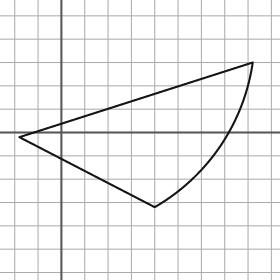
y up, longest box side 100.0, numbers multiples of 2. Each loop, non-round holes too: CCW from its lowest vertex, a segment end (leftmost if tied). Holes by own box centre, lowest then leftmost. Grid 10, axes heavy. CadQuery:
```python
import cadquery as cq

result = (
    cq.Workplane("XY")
    .moveTo(40.0, -32.0)
    .threePointArc((68.0, -6.0), (82.0, 30.0))
    .lineTo(-18.0, -2.0)
    .close()
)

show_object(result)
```